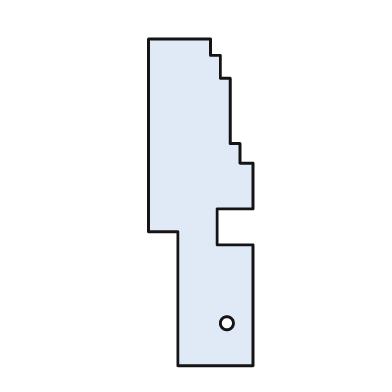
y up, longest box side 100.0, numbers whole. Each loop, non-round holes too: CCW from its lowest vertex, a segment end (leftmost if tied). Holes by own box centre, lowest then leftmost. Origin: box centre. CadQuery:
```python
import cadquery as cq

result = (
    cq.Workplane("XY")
    .moveTo(-7.0, -50.0)
    .lineTo(16.0, -50.0)
    .lineTo(16.0, -13.0)
    .lineTo(5.0, -13.0)
    .lineTo(5.0, -2.0)
    .lineTo(16.0, -2.0)
    .lineTo(16.0, 12.0)
    .lineTo(12.0, 12.0)
    .lineTo(12.0, 18.0)
    .lineTo(9.0, 18.0)
    .lineTo(9.0, 38.0)
    .lineTo(6.0, 38.0)
    .lineTo(6.0, 45.0)
    .lineTo(3.0, 45.0)
    .lineTo(3.0, 50.0)
    .lineTo(-16.0, 50.0)
    .lineTo(-16.0, -9.0)
    .lineTo(-7.0, -9.0)
    .close()
    .moveTo(8.0, -37.0)
    .circle(2.0)
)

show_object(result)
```